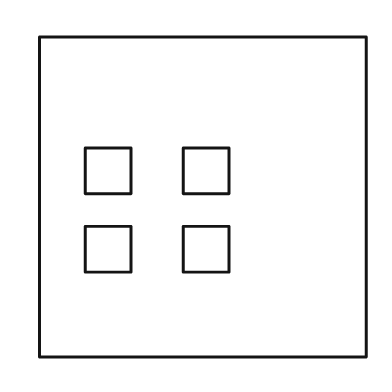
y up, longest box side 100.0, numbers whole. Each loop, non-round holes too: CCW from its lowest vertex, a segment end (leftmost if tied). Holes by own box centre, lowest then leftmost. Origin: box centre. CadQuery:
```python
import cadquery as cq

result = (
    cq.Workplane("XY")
    .moveTo(-50.0, -49.0)
    .lineTo(50.0, -49.0)
    .lineTo(50.0, 49.0)
    .lineTo(-50.0, 49.0)
    .close()
    .moveTo(-36.0, -23.0)
    .lineTo(-22.0, -23.0)
    .lineTo(-22.0, -9.0)
    .lineTo(-36.0, -9.0)
    .close()
    .moveTo(-6.0, -23.0)
    .lineTo(8.0, -23.0)
    .lineTo(8.0, -9.0)
    .lineTo(-6.0, -9.0)
    .close()
    .moveTo(-36.0, 1.0)
    .lineTo(-22.0, 1.0)
    .lineTo(-22.0, 15.0)
    .lineTo(-36.0, 15.0)
    .close()
    .moveTo(-6.0, 1.0)
    .lineTo(8.0, 1.0)
    .lineTo(8.0, 15.0)
    .lineTo(-6.0, 15.0)
    .close()
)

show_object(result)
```